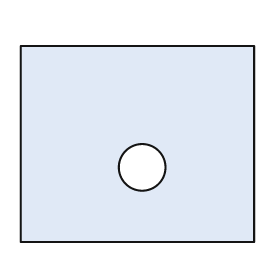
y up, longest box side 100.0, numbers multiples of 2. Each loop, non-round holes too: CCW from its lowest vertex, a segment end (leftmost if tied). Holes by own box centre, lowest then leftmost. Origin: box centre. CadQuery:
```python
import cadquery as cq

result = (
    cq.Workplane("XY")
    .moveTo(-50.0, -42.0)
    .lineTo(50.0, -42.0)
    .lineTo(50.0, 42.0)
    .lineTo(-50.0, 42.0)
    .close()
    .moveTo(2.0, -10.0)
    .circle(10.0)
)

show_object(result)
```